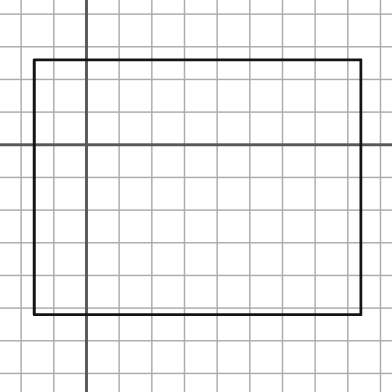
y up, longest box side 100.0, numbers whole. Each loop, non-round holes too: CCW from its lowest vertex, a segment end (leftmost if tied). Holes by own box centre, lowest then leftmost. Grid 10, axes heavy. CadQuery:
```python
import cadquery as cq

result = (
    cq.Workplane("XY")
    .moveTo(-16.0, -52.0)
    .lineTo(84.0, -52.0)
    .lineTo(84.0, 26.0)
    .lineTo(-16.0, 26.0)
    .close()
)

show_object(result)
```